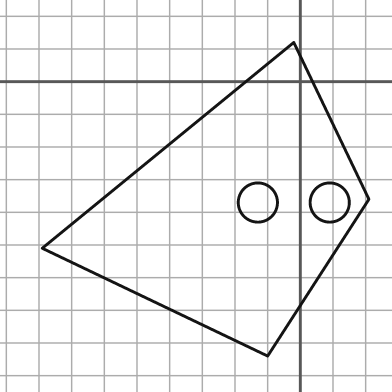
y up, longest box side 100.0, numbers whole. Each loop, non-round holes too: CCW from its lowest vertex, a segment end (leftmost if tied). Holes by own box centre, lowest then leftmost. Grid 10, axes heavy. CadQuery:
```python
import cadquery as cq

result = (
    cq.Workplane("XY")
    .moveTo(-10.0, -84.0)
    .lineTo(21.0, -36.0)
    .lineTo(-2.0, 12.0)
    .lineTo(-79.0, -51.0)
    .close()
    .moveTo(-13.0, -37.0)
    .circle(6.0)
    .moveTo(9.0, -37.0)
    .circle(6.0)
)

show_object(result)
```